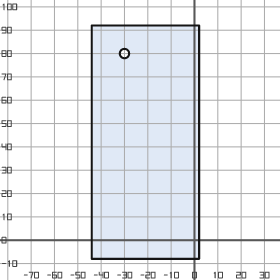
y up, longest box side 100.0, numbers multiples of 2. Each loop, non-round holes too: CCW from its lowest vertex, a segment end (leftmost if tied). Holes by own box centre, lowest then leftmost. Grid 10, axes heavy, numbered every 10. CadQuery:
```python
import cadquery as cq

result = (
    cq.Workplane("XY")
    .moveTo(-44.0, -8.0)
    .lineTo(2.0, -8.0)
    .lineTo(2.0, 92.0)
    .lineTo(-44.0, 92.0)
    .close()
    .moveTo(-30.0, 80.0)
    .circle(2.0)
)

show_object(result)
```